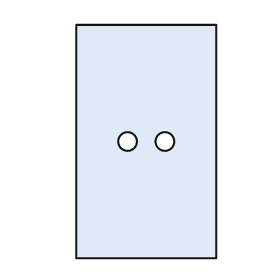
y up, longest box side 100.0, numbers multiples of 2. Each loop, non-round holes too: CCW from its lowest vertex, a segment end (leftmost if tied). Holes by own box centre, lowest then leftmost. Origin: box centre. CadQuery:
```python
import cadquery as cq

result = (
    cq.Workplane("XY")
    .moveTo(-30.0, -50.0)
    .lineTo(30.0, -50.0)
    .lineTo(30.0, 50.0)
    .lineTo(-30.0, 50.0)
    .close()
    .moveTo(-8.0, 0.0)
    .circle(4.0)
    .moveTo(8.0, 0.0)
    .circle(4.0)
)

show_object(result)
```